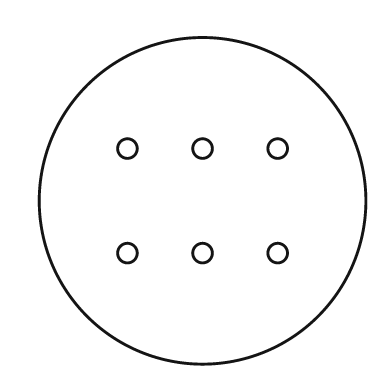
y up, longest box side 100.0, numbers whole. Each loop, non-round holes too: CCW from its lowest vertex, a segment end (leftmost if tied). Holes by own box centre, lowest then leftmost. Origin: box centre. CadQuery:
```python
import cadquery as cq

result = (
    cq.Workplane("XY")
    .moveTo(0.0, 0.0)
    .circle(50.0)
    .moveTo(-23.0, -16.0)
    .circle(3.0)
    .moveTo(0.0, -16.0)
    .circle(3.0)
    .moveTo(23.0, -16.0)
    .circle(3.0)
    .moveTo(-23.0, 16.0)
    .circle(3.0)
    .moveTo(0.0, 16.0)
    .circle(3.0)
    .moveTo(23.0, 16.0)
    .circle(3.0)
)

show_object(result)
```